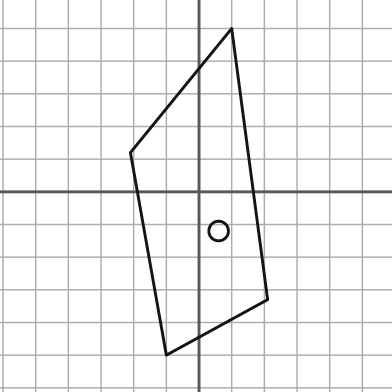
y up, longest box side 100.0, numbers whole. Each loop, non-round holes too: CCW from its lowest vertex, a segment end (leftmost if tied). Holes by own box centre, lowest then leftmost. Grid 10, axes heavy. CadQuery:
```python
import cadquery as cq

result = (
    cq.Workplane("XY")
    .moveTo(-10.0, -50.0)
    .lineTo(21.0, -33.0)
    .lineTo(10.0, 50.0)
    .lineTo(-21.0, 12.0)
    .close()
    .moveTo(6.0, -12.0)
    .circle(3.0)
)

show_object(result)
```